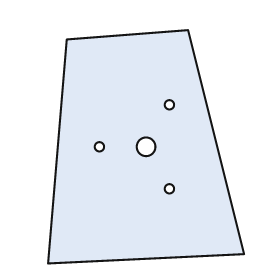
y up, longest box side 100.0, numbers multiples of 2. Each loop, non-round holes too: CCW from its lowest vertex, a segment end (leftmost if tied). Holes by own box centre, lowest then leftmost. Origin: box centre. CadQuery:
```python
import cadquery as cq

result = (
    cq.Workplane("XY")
    .moveTo(-42.0, -50.0)
    .lineTo(42.0, -46.0)
    .lineTo(18.0, 50.0)
    .lineTo(-34.0, 46.0)
    .close()
    .moveTo(10.0, -18.0)
    .circle(2.0)
    .moveTo(-20.0, 0.0)
    .circle(2.0)
    .moveTo(0.0, 0.0)
    .circle(4.0)
    .moveTo(10.0, 18.0)
    .circle(2.0)
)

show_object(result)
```